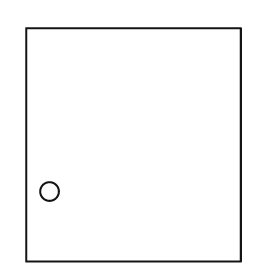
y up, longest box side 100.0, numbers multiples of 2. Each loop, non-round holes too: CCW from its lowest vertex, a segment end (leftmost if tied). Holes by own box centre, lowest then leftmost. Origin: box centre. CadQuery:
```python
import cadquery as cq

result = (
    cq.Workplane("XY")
    .moveTo(-46.0, -50.0)
    .lineTo(46.0, -50.0)
    .lineTo(46.0, 50.0)
    .lineTo(-46.0, 50.0)
    .close()
    .moveTo(-36.0, -20.0)
    .circle(4.0)
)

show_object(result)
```